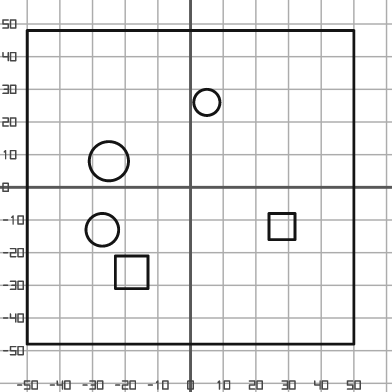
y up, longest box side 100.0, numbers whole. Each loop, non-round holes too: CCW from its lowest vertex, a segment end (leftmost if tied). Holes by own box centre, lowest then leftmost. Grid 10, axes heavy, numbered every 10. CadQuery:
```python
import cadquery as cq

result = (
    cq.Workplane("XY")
    .moveTo(-50.0, -48.0)
    .lineTo(50.0, -48.0)
    .lineTo(50.0, 48.0)
    .lineTo(-50.0, 48.0)
    .close()
    .moveTo(-23.0, -31.0)
    .lineTo(-13.0, -31.0)
    .lineTo(-13.0, -21.0)
    .lineTo(-23.0, -21.0)
    .close()
    .moveTo(-27.0, -13.0)
    .circle(5.0)
    .moveTo(24.0, -16.0)
    .lineTo(32.0, -16.0)
    .lineTo(32.0, -8.0)
    .lineTo(24.0, -8.0)
    .close()
    .moveTo(-25.0, 8.0)
    .circle(6.0)
    .moveTo(5.0, 26.0)
    .circle(4.0)
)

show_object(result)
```